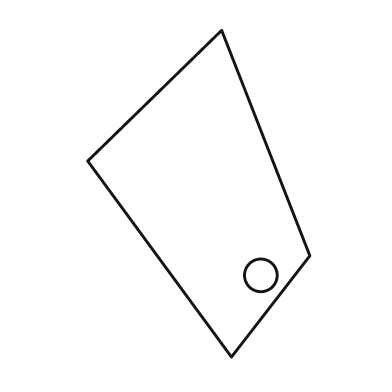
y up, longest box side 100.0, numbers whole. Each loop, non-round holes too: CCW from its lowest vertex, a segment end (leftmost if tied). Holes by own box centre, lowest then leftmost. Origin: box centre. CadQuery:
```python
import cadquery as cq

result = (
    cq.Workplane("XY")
    .moveTo(10.0, -50.0)
    .lineTo(34.0, -19.0)
    .lineTo(7.0, 50.0)
    .lineTo(-34.0, 10.0)
    .close()
    .moveTo(19.0, -25.0)
    .circle(5.0)
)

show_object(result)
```